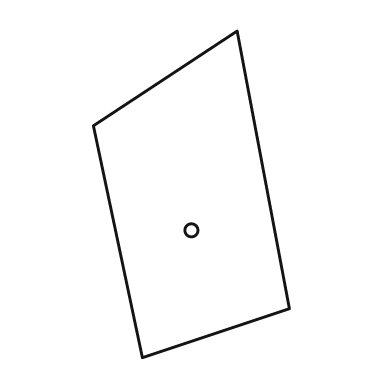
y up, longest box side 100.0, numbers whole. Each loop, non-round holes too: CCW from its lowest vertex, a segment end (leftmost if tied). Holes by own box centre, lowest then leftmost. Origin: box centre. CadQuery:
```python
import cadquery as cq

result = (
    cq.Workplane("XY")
    .moveTo(-15.0, -50.0)
    .lineTo(30.0, -35.0)
    .lineTo(14.0, 50.0)
    .lineTo(-30.0, 21.0)
    .close()
    .moveTo(0.0, -11.0)
    .circle(2.0)
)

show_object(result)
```